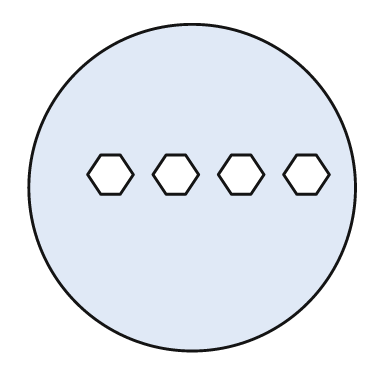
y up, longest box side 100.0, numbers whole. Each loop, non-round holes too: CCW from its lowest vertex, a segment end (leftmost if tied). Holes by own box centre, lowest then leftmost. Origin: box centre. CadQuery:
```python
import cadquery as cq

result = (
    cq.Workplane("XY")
    .moveTo(0.0, 0.0)
    .circle(50.0)
    .moveTo(-28.0, -2.0)
    .lineTo(-22.0, -2.0)
    .lineTo(-18.0, 4.0)
    .lineTo(-22.0, 10.0)
    .lineTo(-28.0, 10.0)
    .lineTo(-32.0, 4.0)
    .close()
    .moveTo(-8.0, -2.0)
    .lineTo(-2.0, -2.0)
    .lineTo(2.0, 4.0)
    .lineTo(-2.0, 10.0)
    .lineTo(-8.0, 10.0)
    .lineTo(-12.0, 4.0)
    .close()
    .moveTo(12.0, -2.0)
    .lineTo(18.0, -2.0)
    .lineTo(22.0, 4.0)
    .lineTo(18.0, 10.0)
    .lineTo(12.0, 10.0)
    .lineTo(8.0, 4.0)
    .close()
    .moveTo(32.0, -2.0)
    .lineTo(38.0, -2.0)
    .lineTo(42.0, 4.0)
    .lineTo(38.0, 10.0)
    .lineTo(32.0, 10.0)
    .lineTo(28.0, 4.0)
    .close()
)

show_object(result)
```